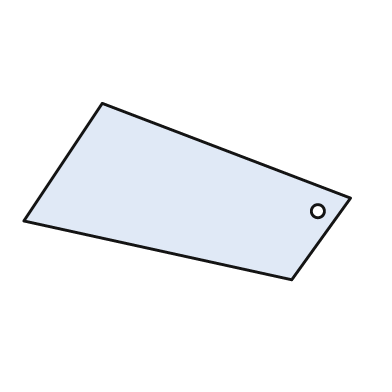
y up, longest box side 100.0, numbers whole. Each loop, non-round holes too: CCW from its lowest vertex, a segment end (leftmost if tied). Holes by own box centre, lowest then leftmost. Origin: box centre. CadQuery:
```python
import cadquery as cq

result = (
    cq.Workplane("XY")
    .moveTo(32.0, -27.0)
    .lineTo(50.0, -2.0)
    .lineTo(-26.0, 27.0)
    .lineTo(-50.0, -9.0)
    .close()
    .moveTo(40.0, -6.0)
    .circle(2.0)
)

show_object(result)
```